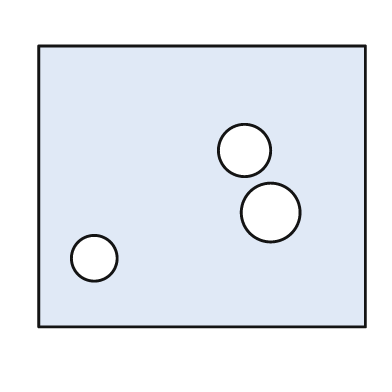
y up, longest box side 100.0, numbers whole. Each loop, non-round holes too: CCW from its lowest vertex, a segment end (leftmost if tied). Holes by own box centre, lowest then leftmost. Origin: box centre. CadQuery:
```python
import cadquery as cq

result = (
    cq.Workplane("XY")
    .moveTo(-50.0, -43.0)
    .lineTo(50.0, -43.0)
    .lineTo(50.0, 43.0)
    .lineTo(-50.0, 43.0)
    .close()
    .moveTo(-33.0, -22.0)
    .circle(7.0)
    .moveTo(21.0, -8.0)
    .circle(9.0)
    .moveTo(13.0, 11.0)
    .circle(8.0)
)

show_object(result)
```